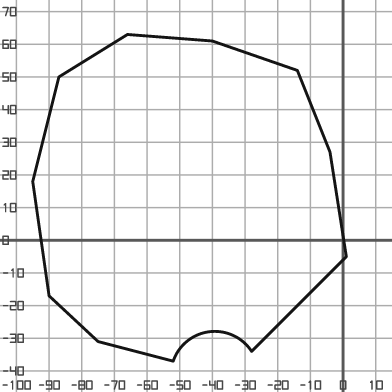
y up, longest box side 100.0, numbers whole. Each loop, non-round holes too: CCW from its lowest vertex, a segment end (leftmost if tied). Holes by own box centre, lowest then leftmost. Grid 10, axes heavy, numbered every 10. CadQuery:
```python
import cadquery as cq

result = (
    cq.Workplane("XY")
    .moveTo(-52.0, -37.0)
    .threePointArc((-41.0, -28.0), (-28.0, -34.0))
    .lineTo(1.0, -5.0)
    .lineTo(-4.0, 27.0)
    .lineTo(-14.0, 52.0)
    .lineTo(-40.0, 61.0)
    .lineTo(-66.0, 63.0)
    .lineTo(-87.0, 50.0)
    .lineTo(-95.0, 18.0)
    .lineTo(-90.0, -17.0)
    .lineTo(-75.0, -31.0)
    .close()
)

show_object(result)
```